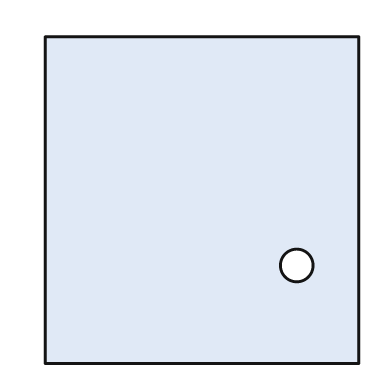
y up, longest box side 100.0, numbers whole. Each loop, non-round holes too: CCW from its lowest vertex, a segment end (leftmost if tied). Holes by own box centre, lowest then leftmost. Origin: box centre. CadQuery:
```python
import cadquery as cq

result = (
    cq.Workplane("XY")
    .moveTo(-48.0, -50.0)
    .lineTo(48.0, -50.0)
    .lineTo(48.0, 50.0)
    .lineTo(-48.0, 50.0)
    .close()
    .moveTo(29.0, -20.0)
    .circle(5.0)
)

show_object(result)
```